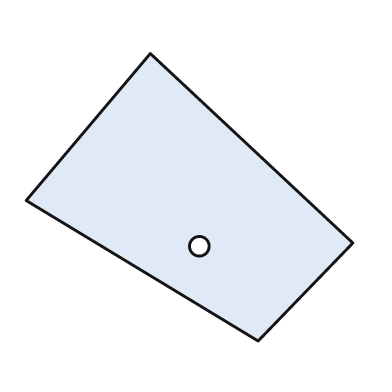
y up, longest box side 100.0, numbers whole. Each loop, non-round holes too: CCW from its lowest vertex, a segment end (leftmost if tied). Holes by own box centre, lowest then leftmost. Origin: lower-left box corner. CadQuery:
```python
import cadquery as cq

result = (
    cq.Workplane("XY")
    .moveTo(71.0, 0.0)
    .lineTo(100.0, 30.0)
    .lineTo(38.0, 88.0)
    .lineTo(0.0, 43.0)
    .close()
    .moveTo(53.0, 29.0)
    .circle(3.0)
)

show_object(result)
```